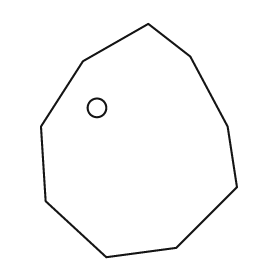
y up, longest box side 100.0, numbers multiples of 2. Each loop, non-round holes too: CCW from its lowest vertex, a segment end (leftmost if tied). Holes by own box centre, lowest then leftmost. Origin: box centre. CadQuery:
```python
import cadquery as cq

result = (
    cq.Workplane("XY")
    .moveTo(-14.0, -50.0)
    .lineTo(16.0, -46.0)
    .lineTo(42.0, -20.0)
    .lineTo(38.0, 6.0)
    .lineTo(22.0, 36.0)
    .lineTo(4.0, 50.0)
    .lineTo(-24.0, 34.0)
    .lineTo(-42.0, 6.0)
    .lineTo(-40.0, -26.0)
    .close()
    .moveTo(-18.0, 14.0)
    .circle(4.0)
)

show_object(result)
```